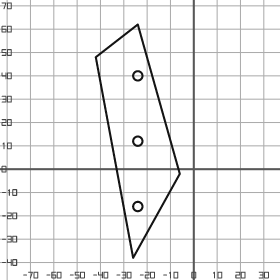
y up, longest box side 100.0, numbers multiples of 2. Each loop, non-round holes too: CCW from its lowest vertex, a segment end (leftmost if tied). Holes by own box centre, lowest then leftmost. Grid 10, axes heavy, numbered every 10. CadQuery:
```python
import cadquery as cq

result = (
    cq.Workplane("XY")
    .moveTo(-26.0, -38.0)
    .lineTo(-6.0, -2.0)
    .lineTo(-24.0, 62.0)
    .lineTo(-42.0, 48.0)
    .close()
    .moveTo(-24.0, -16.0)
    .circle(2.0)
    .moveTo(-24.0, 12.0)
    .circle(2.0)
    .moveTo(-24.0, 40.0)
    .circle(2.0)
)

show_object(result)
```